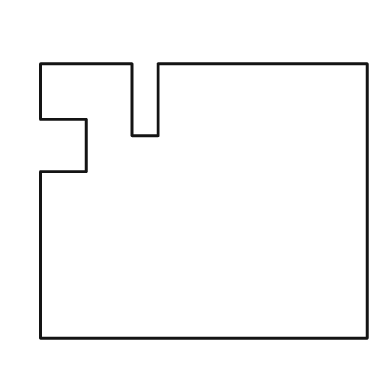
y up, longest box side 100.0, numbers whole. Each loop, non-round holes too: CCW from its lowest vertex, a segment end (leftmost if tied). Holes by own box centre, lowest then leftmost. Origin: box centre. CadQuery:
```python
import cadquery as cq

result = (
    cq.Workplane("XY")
    .moveTo(-50.0, -42.0)
    .lineTo(50.0, -42.0)
    .lineTo(50.0, 42.0)
    .lineTo(-14.0, 42.0)
    .lineTo(-14.0, 20.0)
    .lineTo(-22.0, 20.0)
    .lineTo(-22.0, 42.0)
    .lineTo(-50.0, 42.0)
    .lineTo(-50.0, 25.0)
    .lineTo(-36.0, 25.0)
    .lineTo(-36.0, 9.0)
    .lineTo(-50.0, 9.0)
    .close()
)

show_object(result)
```